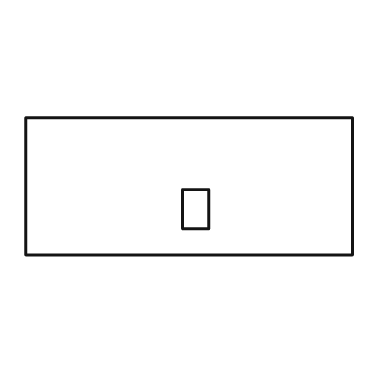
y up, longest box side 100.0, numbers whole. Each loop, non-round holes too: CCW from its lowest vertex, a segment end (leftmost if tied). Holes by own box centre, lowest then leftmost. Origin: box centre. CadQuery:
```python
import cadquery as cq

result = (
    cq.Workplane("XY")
    .moveTo(-50.0, -21.0)
    .lineTo(50.0, -21.0)
    .lineTo(50.0, 21.0)
    .lineTo(-50.0, 21.0)
    .close()
    .moveTo(-2.0, -13.0)
    .lineTo(6.0, -13.0)
    .lineTo(6.0, -1.0)
    .lineTo(-2.0, -1.0)
    .close()
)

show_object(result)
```